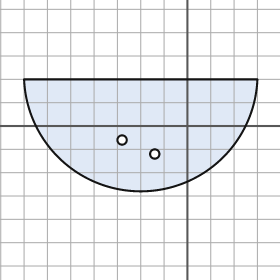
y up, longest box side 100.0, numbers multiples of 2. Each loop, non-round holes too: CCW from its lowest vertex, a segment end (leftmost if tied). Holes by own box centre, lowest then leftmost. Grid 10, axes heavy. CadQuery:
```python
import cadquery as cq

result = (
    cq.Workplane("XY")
    .moveTo(-70.0, 20.0)
    .threePointArc((-20.0, -28.0), (30.0, 20.0))
    .close()
    .moveTo(-14.0, -12.0)
    .circle(2.0)
    .moveTo(-28.0, -6.0)
    .circle(2.0)
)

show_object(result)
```